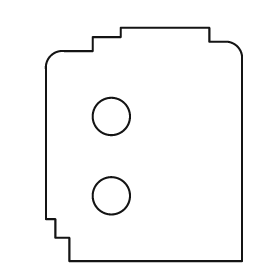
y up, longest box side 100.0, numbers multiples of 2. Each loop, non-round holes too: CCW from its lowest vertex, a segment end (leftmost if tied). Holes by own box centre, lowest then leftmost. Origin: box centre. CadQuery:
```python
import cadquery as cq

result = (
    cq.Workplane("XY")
    .moveTo(-32.0, -50.0)
    .lineTo(42.0, -50.0)
    .lineTo(42.0, 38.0)
    .threePointArc((40.0, 42.0), (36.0, 44.0))
    .lineTo(28.0, 44.0)
    .lineTo(28.0, 50.0)
    .lineTo(-10.0, 50.0)
    .lineTo(-10.0, 46.0)
    .lineTo(-22.0, 46.0)
    .lineTo(-22.0, 40.0)
    .lineTo(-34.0, 40.0)
    .threePointArc((-40.0, 38.0), (-42.0, 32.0))
    .lineTo(-42.0, -32.0)
    .lineTo(-38.0, -32.0)
    .lineTo(-38.0, -40.0)
    .lineTo(-32.0, -40.0)
    .close()
    .moveTo(-14.0, -22.0)
    .circle(8.0)
    .moveTo(-14.0, 12.0)
    .circle(8.0)
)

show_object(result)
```